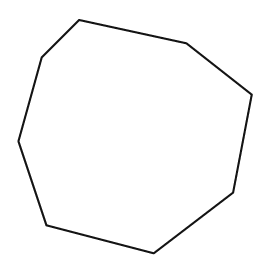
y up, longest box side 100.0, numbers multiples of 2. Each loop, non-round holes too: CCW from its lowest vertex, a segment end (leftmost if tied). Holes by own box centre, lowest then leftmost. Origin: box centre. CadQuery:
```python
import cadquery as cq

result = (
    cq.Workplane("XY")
    .moveTo(8.0, -50.0)
    .lineTo(42.0, -24.0)
    .lineTo(50.0, 18.0)
    .lineTo(22.0, 40.0)
    .lineTo(-24.0, 50.0)
    .lineTo(-40.0, 34.0)
    .lineTo(-50.0, -2.0)
    .lineTo(-38.0, -38.0)
    .close()
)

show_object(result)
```